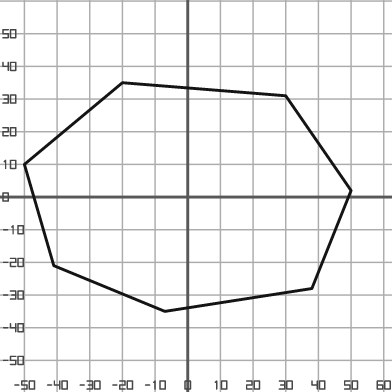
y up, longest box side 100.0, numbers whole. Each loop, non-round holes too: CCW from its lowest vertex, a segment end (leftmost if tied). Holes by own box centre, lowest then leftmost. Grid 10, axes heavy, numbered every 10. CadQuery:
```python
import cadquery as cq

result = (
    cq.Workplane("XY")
    .moveTo(-7.0, -35.0)
    .lineTo(38.0, -28.0)
    .lineTo(50.0, 2.0)
    .lineTo(30.0, 31.0)
    .lineTo(-20.0, 35.0)
    .lineTo(-50.0, 10.0)
    .lineTo(-41.0, -21.0)
    .close()
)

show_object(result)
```